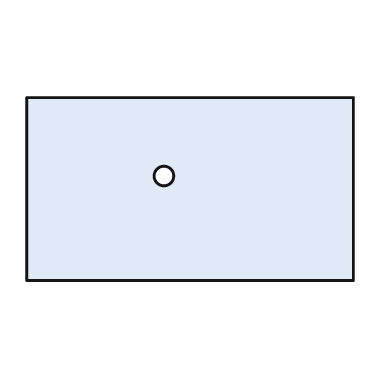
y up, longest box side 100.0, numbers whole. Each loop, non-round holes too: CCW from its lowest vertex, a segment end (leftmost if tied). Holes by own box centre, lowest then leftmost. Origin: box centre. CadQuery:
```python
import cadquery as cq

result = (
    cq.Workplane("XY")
    .moveTo(-50.0, -28.0)
    .lineTo(50.0, -28.0)
    .lineTo(50.0, 28.0)
    .lineTo(-50.0, 28.0)
    .close()
    .moveTo(-8.0, 4.0)
    .circle(3.0)
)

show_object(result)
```